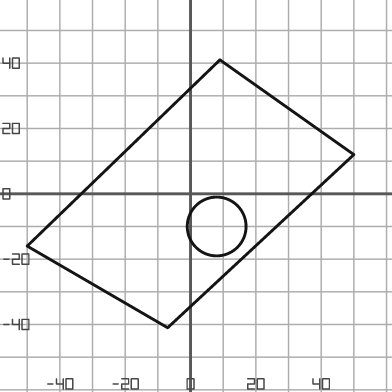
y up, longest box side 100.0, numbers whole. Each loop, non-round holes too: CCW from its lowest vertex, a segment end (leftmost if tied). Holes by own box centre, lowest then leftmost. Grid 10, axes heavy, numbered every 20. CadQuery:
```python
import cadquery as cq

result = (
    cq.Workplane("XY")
    .moveTo(-7.0, -41.0)
    .lineTo(50.0, 12.0)
    .lineTo(9.0, 41.0)
    .lineTo(-50.0, -16.0)
    .close()
    .moveTo(8.0, -10.0)
    .circle(9.0)
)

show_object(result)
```